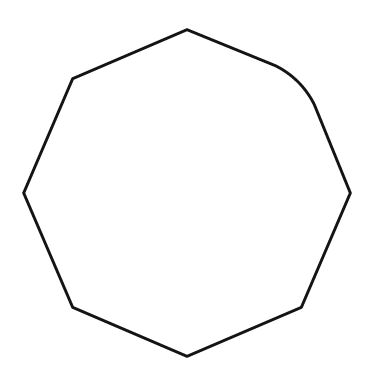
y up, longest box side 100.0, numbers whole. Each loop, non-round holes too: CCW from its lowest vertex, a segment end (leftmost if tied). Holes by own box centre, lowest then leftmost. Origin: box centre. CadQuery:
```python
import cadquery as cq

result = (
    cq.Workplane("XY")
    .moveTo(0.0, -50.0)
    .lineTo(35.0, -35.0)
    .lineTo(50.0, 0.0)
    .lineTo(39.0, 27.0)
    .threePointArc((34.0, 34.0), (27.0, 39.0))
    .lineTo(0.0, 50.0)
    .lineTo(-35.0, 35.0)
    .lineTo(-50.0, 0.0)
    .lineTo(-35.0, -35.0)
    .close()
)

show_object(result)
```